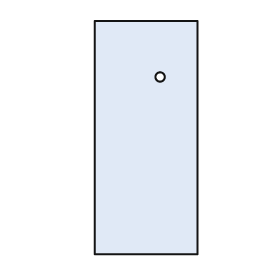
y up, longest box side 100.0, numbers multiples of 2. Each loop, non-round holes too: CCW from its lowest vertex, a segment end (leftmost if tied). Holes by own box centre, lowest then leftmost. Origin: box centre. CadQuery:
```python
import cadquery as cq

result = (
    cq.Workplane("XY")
    .moveTo(-22.0, -50.0)
    .lineTo(22.0, -50.0)
    .lineTo(22.0, 50.0)
    .lineTo(-22.0, 50.0)
    .close()
    .moveTo(6.0, 26.0)
    .circle(2.0)
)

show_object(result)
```